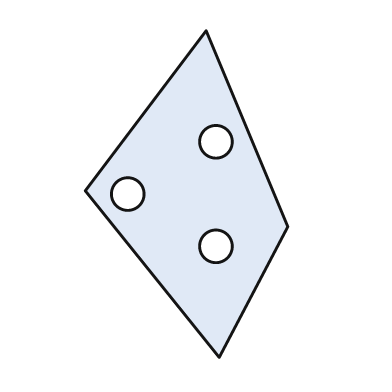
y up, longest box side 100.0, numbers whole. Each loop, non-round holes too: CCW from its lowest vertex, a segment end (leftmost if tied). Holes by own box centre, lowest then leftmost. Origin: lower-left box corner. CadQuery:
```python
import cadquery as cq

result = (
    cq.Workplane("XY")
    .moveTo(41.0, 0.0)
    .lineTo(62.0, 40.0)
    .lineTo(37.0, 100.0)
    .lineTo(0.0, 51.0)
    .close()
    .moveTo(40.0, 34.0)
    .circle(5.0)
    .moveTo(13.0, 50.0)
    .circle(5.0)
    .moveTo(40.0, 66.0)
    .circle(5.0)
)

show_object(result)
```